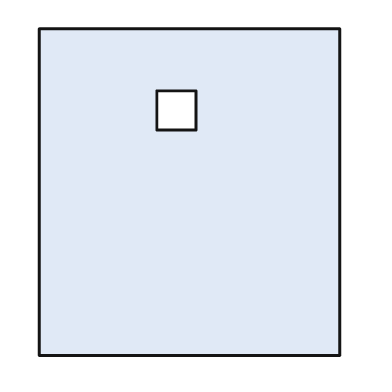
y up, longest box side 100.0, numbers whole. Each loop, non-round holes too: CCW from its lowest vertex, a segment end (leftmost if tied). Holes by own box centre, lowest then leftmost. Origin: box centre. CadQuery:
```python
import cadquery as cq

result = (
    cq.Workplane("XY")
    .moveTo(-46.0, -50.0)
    .lineTo(46.0, -50.0)
    .lineTo(46.0, 50.0)
    .lineTo(-46.0, 50.0)
    .close()
    .moveTo(-10.0, 19.0)
    .lineTo(2.0, 19.0)
    .lineTo(2.0, 31.0)
    .lineTo(-10.0, 31.0)
    .close()
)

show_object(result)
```